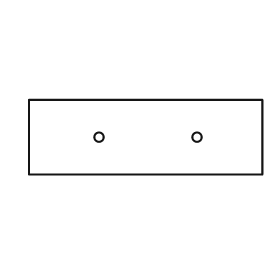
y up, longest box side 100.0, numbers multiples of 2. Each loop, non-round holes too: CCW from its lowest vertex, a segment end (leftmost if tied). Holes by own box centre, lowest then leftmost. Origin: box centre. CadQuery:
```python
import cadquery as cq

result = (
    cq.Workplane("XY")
    .moveTo(-50.0, -16.0)
    .lineTo(50.0, -16.0)
    .lineTo(50.0, 16.0)
    .lineTo(-50.0, 16.0)
    .close()
    .moveTo(-20.0, 0.0)
    .circle(2.0)
    .moveTo(22.0, 0.0)
    .circle(2.0)
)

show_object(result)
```